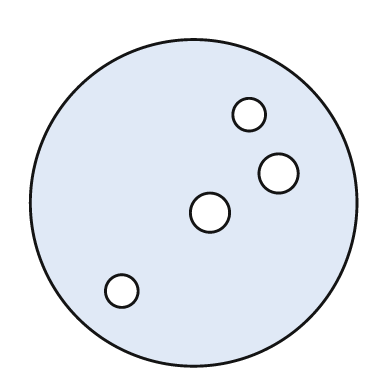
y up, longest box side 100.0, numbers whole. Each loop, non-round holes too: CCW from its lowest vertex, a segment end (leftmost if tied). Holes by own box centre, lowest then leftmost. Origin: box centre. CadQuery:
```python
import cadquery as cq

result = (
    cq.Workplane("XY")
    .moveTo(0.0, 0.0)
    .circle(50.0)
    .moveTo(-22.0, -27.0)
    .circle(5.0)
    .moveTo(5.0, -3.0)
    .circle(6.0)
    .moveTo(26.0, 9.0)
    .circle(6.0)
    .moveTo(17.0, 27.0)
    .circle(5.0)
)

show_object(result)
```